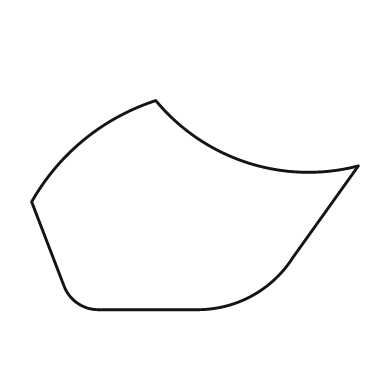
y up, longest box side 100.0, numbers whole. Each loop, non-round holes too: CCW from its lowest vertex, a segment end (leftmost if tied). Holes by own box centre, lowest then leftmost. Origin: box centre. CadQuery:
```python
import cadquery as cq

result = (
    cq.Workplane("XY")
    .moveTo(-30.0, -32.0)
    .lineTo(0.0, -32.0)
    .threePointArc((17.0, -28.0), (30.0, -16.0))
    .lineTo(50.0, 12.0)
    .threePointArc((16.0, 13.0), (-12.0, 32.0))
    .threePointArc((-34.0, 20.0), (-50.0, 1.0))
    .lineTo(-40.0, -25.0)
    .threePointArc((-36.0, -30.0), (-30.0, -32.0))
    .close()
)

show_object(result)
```